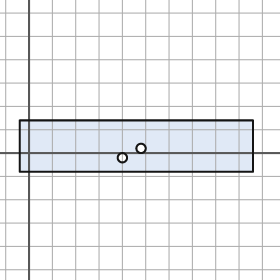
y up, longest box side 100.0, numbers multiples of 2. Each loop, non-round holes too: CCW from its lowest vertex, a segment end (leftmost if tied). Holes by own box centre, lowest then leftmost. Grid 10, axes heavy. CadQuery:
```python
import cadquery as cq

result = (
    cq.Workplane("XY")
    .moveTo(-4.0, -8.0)
    .lineTo(96.0, -8.0)
    .lineTo(96.0, 14.0)
    .lineTo(-4.0, 14.0)
    .close()
    .moveTo(40.0, -2.0)
    .circle(2.0)
    .moveTo(48.0, 2.0)
    .circle(2.0)
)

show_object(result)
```